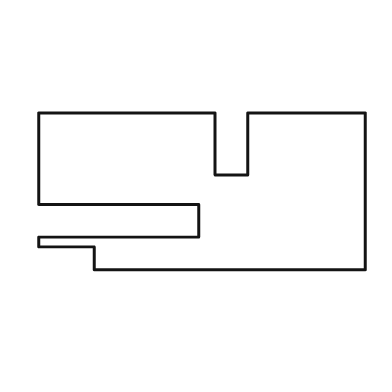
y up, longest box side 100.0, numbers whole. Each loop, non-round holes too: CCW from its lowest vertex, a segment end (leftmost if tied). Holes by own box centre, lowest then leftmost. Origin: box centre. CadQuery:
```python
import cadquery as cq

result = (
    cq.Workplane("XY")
    .moveTo(-33.0, -24.0)
    .lineTo(50.0, -24.0)
    .lineTo(50.0, 24.0)
    .lineTo(14.0, 24.0)
    .lineTo(14.0, 5.0)
    .lineTo(4.0, 5.0)
    .lineTo(4.0, 24.0)
    .lineTo(-50.0, 24.0)
    .lineTo(-50.0, -4.0)
    .lineTo(-1.0, -4.0)
    .lineTo(-1.0, -14.0)
    .lineTo(-50.0, -14.0)
    .lineTo(-50.0, -17.0)
    .lineTo(-33.0, -17.0)
    .close()
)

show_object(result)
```